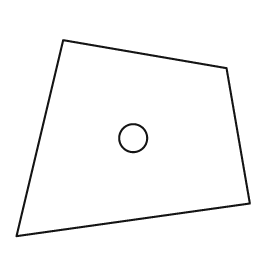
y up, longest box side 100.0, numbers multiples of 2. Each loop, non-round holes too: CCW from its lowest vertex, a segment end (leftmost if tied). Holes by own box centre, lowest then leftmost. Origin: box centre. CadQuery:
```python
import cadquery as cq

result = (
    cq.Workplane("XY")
    .moveTo(-50.0, -42.0)
    .lineTo(50.0, -28.0)
    .lineTo(40.0, 30.0)
    .lineTo(-30.0, 42.0)
    .close()
    .moveTo(0.0, 0.0)
    .circle(6.0)
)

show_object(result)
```